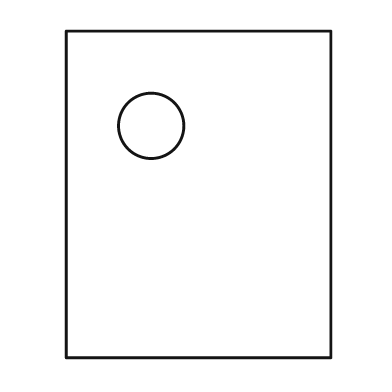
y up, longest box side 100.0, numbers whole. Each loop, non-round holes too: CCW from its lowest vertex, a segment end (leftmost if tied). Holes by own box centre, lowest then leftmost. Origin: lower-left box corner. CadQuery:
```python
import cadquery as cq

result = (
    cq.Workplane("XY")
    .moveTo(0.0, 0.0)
    .lineTo(81.0, 0.0)
    .lineTo(81.0, 100.0)
    .lineTo(0.0, 100.0)
    .close()
    .moveTo(26.0, 71.0)
    .circle(10.0)
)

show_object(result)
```